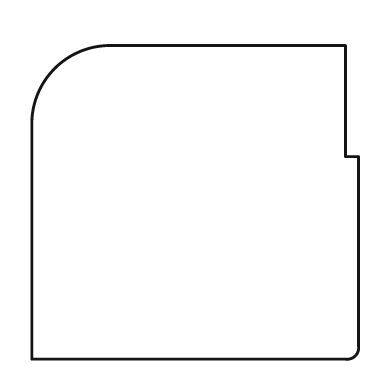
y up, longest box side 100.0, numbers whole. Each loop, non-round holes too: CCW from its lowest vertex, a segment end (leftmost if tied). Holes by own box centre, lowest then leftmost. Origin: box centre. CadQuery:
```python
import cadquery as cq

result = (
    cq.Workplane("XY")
    .moveTo(-50.0, -48.0)
    .lineTo(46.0, -48.0)
    .threePointArc((49.0, -47.0), (50.0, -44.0))
    .lineTo(50.0, 14.0)
    .lineTo(46.0, 14.0)
    .lineTo(46.0, 48.0)
    .lineTo(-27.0, 48.0)
    .threePointArc((-43.0, 41.0), (-50.0, 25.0))
    .close()
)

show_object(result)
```